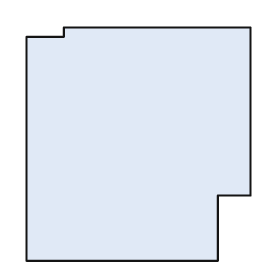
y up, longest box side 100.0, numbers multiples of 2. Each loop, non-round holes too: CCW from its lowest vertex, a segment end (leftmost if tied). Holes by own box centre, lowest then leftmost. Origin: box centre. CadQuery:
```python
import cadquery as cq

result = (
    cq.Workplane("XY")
    .moveTo(-48.0, -50.0)
    .lineTo(34.0, -50.0)
    .lineTo(34.0, -22.0)
    .lineTo(48.0, -22.0)
    .lineTo(48.0, 50.0)
    .lineTo(-32.0, 50.0)
    .lineTo(-32.0, 46.0)
    .lineTo(-48.0, 46.0)
    .close()
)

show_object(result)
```